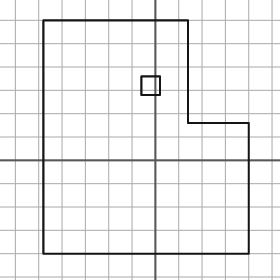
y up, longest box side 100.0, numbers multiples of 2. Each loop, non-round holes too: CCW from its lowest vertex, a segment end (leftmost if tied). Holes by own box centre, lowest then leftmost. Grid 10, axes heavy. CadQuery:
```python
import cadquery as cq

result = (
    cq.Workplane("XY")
    .moveTo(-48.0, -40.0)
    .lineTo(40.0, -40.0)
    .lineTo(40.0, 16.0)
    .lineTo(14.0, 16.0)
    .lineTo(14.0, 60.0)
    .lineTo(-48.0, 60.0)
    .close()
    .moveTo(-6.0, 28.0)
    .lineTo(2.0, 28.0)
    .lineTo(2.0, 36.0)
    .lineTo(-6.0, 36.0)
    .close()
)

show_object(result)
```